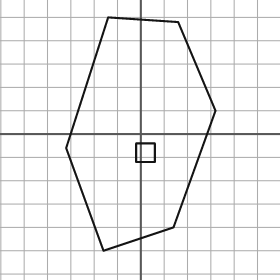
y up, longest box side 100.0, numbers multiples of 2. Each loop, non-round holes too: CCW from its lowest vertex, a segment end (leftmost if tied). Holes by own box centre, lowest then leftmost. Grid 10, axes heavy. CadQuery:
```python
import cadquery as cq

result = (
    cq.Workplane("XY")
    .moveTo(-16.0, -50.0)
    .lineTo(14.0, -40.0)
    .lineTo(32.0, 10.0)
    .lineTo(16.0, 48.0)
    .lineTo(-14.0, 50.0)
    .lineTo(-32.0, -6.0)
    .close()
    .moveTo(-2.0, -12.0)
    .lineTo(6.0, -12.0)
    .lineTo(6.0, -4.0)
    .lineTo(-2.0, -4.0)
    .close()
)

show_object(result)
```